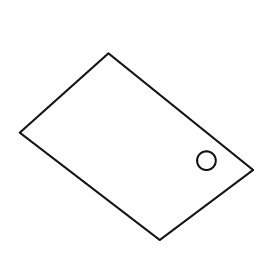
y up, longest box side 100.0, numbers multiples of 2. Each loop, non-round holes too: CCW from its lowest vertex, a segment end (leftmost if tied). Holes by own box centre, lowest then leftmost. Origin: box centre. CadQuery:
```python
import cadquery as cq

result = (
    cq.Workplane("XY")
    .moveTo(10.0, -40.0)
    .lineTo(50.0, -10.0)
    .lineTo(-12.0, 40.0)
    .lineTo(-50.0, 6.0)
    .close()
    .moveTo(30.0, -6.0)
    .circle(4.0)
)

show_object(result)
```